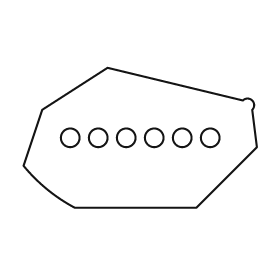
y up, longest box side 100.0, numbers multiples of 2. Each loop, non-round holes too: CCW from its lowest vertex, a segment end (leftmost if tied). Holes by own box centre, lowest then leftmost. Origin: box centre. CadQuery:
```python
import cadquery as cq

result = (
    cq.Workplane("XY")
    .moveTo(-28.0, -30.0)
    .lineTo(24.0, -30.0)
    .lineTo(50.0, -4.0)
    .lineTo(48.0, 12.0)
    .threePointArc((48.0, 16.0), (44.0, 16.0))
    .lineTo(-14.0, 30.0)
    .lineTo(-42.0, 12.0)
    .lineTo(-50.0, -12.0)
    .threePointArc((-40.0, -22.0), (-28.0, -30.0))
    .close()
    .moveTo(-30.0, 0.0)
    .circle(4.0)
    .moveTo(-18.0, 0.0)
    .circle(4.0)
    .moveTo(-6.0, 0.0)
    .circle(4.0)
    .moveTo(6.0, 0.0)
    .circle(4.0)
    .moveTo(18.0, 0.0)
    .circle(4.0)
    .moveTo(30.0, 0.0)
    .circle(4.0)
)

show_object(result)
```